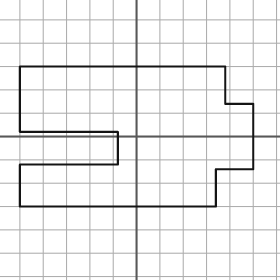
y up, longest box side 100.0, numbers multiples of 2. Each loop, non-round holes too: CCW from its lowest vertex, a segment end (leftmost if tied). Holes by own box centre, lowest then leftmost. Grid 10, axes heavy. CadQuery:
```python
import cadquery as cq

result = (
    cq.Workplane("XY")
    .moveTo(-50.0, -30.0)
    .lineTo(34.0, -30.0)
    .lineTo(34.0, -14.0)
    .lineTo(50.0, -14.0)
    .lineTo(50.0, 14.0)
    .lineTo(38.0, 14.0)
    .lineTo(38.0, 30.0)
    .lineTo(-50.0, 30.0)
    .lineTo(-50.0, 2.0)
    .lineTo(-8.0, 2.0)
    .lineTo(-8.0, -12.0)
    .lineTo(-50.0, -12.0)
    .close()
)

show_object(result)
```